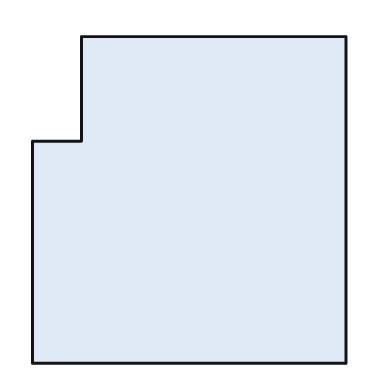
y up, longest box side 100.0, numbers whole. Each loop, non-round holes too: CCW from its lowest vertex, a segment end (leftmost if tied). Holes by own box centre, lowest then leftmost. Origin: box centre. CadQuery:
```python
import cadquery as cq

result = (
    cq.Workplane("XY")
    .moveTo(-48.0, -50.0)
    .lineTo(48.0, -50.0)
    .lineTo(48.0, 50.0)
    .lineTo(-33.0, 50.0)
    .lineTo(-33.0, 18.0)
    .lineTo(-48.0, 18.0)
    .close()
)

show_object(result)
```